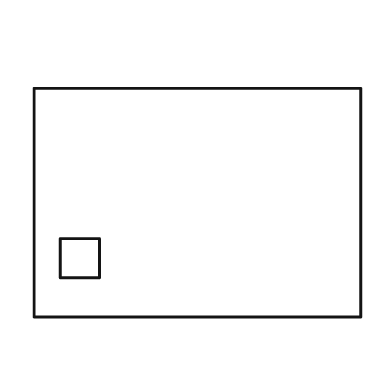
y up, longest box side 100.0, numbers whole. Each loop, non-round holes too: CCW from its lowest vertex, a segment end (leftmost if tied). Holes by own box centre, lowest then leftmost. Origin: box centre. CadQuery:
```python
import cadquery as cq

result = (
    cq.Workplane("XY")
    .moveTo(-50.0, -35.0)
    .lineTo(50.0, -35.0)
    .lineTo(50.0, 35.0)
    .lineTo(-50.0, 35.0)
    .close()
    .moveTo(-42.0, -23.0)
    .lineTo(-30.0, -23.0)
    .lineTo(-30.0, -11.0)
    .lineTo(-42.0, -11.0)
    .close()
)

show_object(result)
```